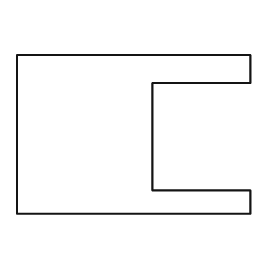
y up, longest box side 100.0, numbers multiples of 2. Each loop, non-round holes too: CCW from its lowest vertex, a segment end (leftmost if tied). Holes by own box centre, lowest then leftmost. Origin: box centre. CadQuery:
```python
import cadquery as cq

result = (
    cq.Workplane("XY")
    .moveTo(-50.0, -34.0)
    .lineTo(50.0, -34.0)
    .lineTo(50.0, -24.0)
    .lineTo(8.0, -24.0)
    .lineTo(8.0, 22.0)
    .lineTo(50.0, 22.0)
    .lineTo(50.0, 34.0)
    .lineTo(-50.0, 34.0)
    .close()
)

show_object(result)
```